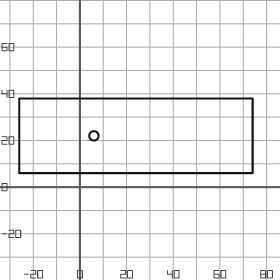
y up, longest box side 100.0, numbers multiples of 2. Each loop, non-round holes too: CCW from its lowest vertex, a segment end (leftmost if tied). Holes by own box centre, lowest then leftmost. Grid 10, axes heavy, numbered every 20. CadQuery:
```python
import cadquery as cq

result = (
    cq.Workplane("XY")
    .moveTo(-26.0, 6.0)
    .lineTo(74.0, 6.0)
    .lineTo(74.0, 38.0)
    .lineTo(-26.0, 38.0)
    .close()
    .moveTo(6.0, 22.0)
    .circle(2.0)
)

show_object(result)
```